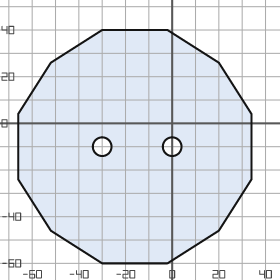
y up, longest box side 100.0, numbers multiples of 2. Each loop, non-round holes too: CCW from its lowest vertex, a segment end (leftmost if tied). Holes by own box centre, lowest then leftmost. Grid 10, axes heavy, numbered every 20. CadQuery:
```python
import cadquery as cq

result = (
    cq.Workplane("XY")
    .moveTo(-30.0, -60.0)
    .lineTo(-2.0, -60.0)
    .lineTo(20.0, -46.0)
    .lineTo(34.0, -24.0)
    .lineTo(34.0, 4.0)
    .lineTo(20.0, 26.0)
    .lineTo(-2.0, 40.0)
    .lineTo(-30.0, 40.0)
    .lineTo(-52.0, 26.0)
    .lineTo(-66.0, 4.0)
    .lineTo(-66.0, -24.0)
    .lineTo(-52.0, -46.0)
    .close()
    .moveTo(-30.0, -10.0)
    .circle(4.0)
    .moveTo(0.0, -10.0)
    .circle(4.0)
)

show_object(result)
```